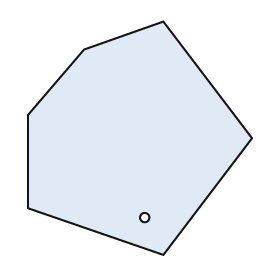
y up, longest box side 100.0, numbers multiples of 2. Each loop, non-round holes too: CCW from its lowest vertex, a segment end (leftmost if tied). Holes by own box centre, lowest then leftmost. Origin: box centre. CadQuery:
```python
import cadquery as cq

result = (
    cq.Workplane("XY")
    .moveTo(10.0, -50.0)
    .lineTo(48.0, 0.0)
    .lineTo(10.0, 50.0)
    .lineTo(-24.0, 38.0)
    .lineTo(-48.0, 10.0)
    .lineTo(-48.0, -30.0)
    .close()
    .moveTo(2.0, -34.0)
    .circle(2.0)
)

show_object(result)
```